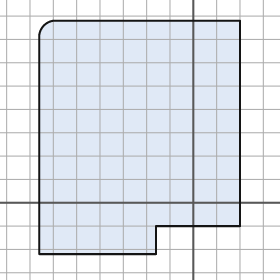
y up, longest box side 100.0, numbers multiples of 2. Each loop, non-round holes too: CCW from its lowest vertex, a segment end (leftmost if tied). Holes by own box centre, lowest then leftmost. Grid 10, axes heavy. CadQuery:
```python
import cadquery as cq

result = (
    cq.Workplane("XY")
    .moveTo(-66.0, -22.0)
    .lineTo(-16.0, -22.0)
    .lineTo(-16.0, -10.0)
    .lineTo(20.0, -10.0)
    .lineTo(20.0, 78.0)
    .lineTo(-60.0, 78.0)
    .threePointArc((-64.0, 76.0), (-66.0, 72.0))
    .close()
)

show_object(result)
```